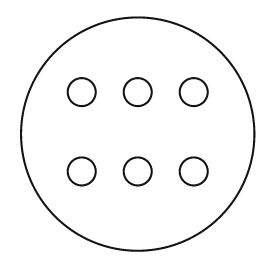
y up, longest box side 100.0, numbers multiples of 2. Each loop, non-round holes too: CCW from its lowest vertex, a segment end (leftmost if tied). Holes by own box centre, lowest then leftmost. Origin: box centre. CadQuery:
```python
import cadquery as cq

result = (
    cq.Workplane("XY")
    .moveTo(0.0, 0.0)
    .circle(50.0)
    .moveTo(-24.0, -16.0)
    .circle(6.0)
    .moveTo(0.0, -16.0)
    .circle(6.0)
    .moveTo(24.0, -16.0)
    .circle(6.0)
    .moveTo(-24.0, 18.0)
    .circle(6.0)
    .moveTo(0.0, 18.0)
    .circle(6.0)
    .moveTo(24.0, 18.0)
    .circle(6.0)
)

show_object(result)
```